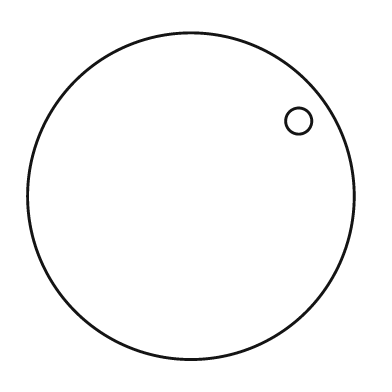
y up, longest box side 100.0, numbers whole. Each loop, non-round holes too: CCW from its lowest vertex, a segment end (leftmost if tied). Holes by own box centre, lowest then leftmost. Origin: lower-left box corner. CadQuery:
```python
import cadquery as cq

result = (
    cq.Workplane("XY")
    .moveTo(50.0, 50.0)
    .circle(50.0)
    .moveTo(83.0, 73.0)
    .circle(4.0)
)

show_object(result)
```